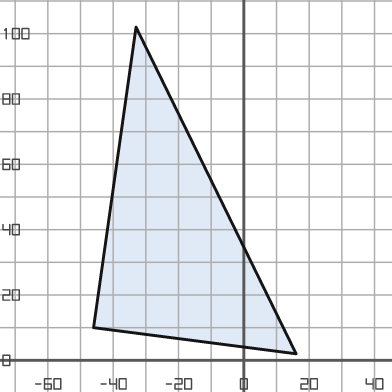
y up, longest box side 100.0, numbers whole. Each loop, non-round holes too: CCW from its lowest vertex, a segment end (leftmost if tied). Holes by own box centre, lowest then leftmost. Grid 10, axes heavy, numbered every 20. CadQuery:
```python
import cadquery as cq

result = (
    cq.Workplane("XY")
    .moveTo(16.0, 2.0)
    .lineTo(-33.0, 102.0)
    .lineTo(-46.0, 10.0)
    .close()
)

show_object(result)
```